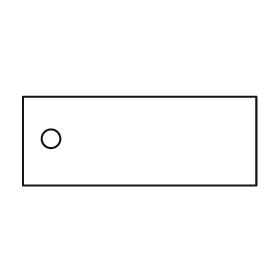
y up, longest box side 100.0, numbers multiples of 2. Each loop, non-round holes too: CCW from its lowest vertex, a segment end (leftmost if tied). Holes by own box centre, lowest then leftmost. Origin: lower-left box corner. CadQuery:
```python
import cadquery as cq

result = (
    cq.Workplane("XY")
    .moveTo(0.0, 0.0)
    .lineTo(100.0, 0.0)
    .lineTo(100.0, 38.0)
    .lineTo(0.0, 38.0)
    .close()
    .moveTo(12.0, 20.0)
    .circle(4.0)
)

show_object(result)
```